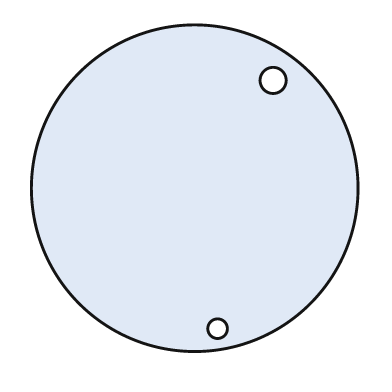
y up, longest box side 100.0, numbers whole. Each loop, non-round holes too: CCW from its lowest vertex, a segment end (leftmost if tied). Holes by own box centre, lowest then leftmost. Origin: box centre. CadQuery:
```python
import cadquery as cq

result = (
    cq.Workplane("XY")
    .moveTo(0.0, 0.0)
    .circle(50.0)
    .moveTo(7.0, -43.0)
    .circle(3.0)
    .moveTo(24.0, 33.0)
    .circle(4.0)
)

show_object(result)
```